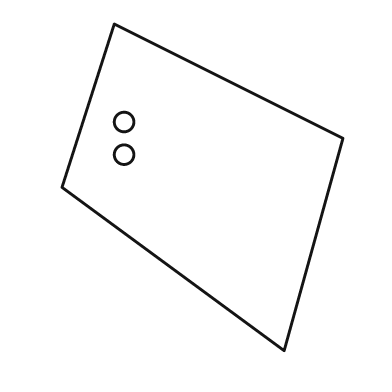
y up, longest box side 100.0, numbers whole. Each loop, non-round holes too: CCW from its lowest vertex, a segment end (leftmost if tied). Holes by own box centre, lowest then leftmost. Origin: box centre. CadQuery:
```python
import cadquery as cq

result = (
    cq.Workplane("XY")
    .moveTo(25.0, -50.0)
    .lineTo(43.0, 15.0)
    .lineTo(-27.0, 50.0)
    .lineTo(-43.0, 0.0)
    .close()
    .moveTo(-24.0, 10.0)
    .circle(3.0)
    .moveTo(-24.0, 20.0)
    .circle(3.0)
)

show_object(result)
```